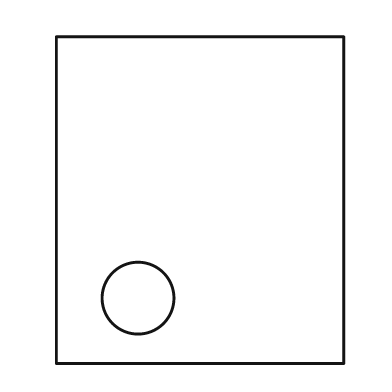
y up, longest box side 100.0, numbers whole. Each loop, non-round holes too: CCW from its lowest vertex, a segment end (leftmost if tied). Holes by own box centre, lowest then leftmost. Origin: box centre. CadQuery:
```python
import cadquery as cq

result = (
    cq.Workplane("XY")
    .moveTo(-44.0, -50.0)
    .lineTo(44.0, -50.0)
    .lineTo(44.0, 50.0)
    .lineTo(-44.0, 50.0)
    .close()
    .moveTo(-19.0, -30.0)
    .circle(11.0)
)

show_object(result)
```